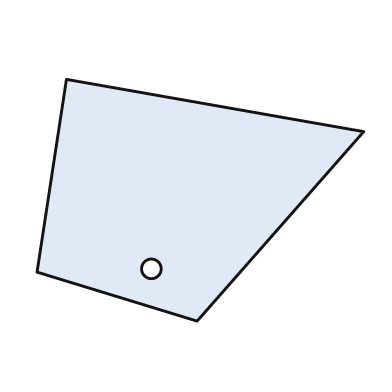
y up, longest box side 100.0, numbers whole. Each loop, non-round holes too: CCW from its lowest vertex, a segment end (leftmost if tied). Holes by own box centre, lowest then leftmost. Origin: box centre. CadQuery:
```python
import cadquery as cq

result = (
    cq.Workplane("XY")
    .moveTo(-1.0, -37.0)
    .lineTo(50.0, 21.0)
    .lineTo(-41.0, 37.0)
    .lineTo(-50.0, -22.0)
    .close()
    .moveTo(-15.0, -21.0)
    .circle(3.0)
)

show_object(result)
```